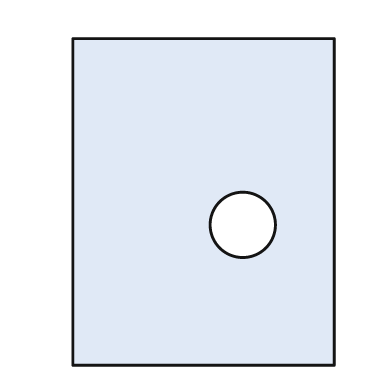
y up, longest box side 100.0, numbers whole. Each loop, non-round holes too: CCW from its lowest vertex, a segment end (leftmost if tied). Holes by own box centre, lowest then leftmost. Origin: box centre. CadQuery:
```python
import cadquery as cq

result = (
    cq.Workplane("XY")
    .moveTo(-40.0, -50.0)
    .lineTo(40.0, -50.0)
    .lineTo(40.0, 50.0)
    .lineTo(-40.0, 50.0)
    .close()
    .moveTo(12.0, -7.0)
    .circle(10.0)
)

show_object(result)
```